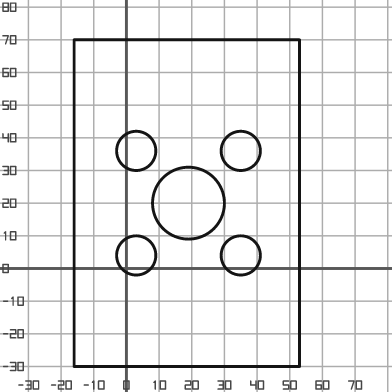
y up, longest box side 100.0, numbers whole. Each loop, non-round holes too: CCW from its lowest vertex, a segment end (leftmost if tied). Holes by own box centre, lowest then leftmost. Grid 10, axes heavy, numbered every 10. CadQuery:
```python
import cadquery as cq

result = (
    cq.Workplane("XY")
    .moveTo(-16.0, -30.0)
    .lineTo(53.0, -30.0)
    .lineTo(53.0, 70.0)
    .lineTo(-16.0, 70.0)
    .close()
    .moveTo(3.0, 4.0)
    .circle(6.0)
    .moveTo(35.0, 4.0)
    .circle(6.0)
    .moveTo(19.0, 20.0)
    .circle(11.0)
    .moveTo(3.0, 36.0)
    .circle(6.0)
    .moveTo(35.0, 36.0)
    .circle(6.0)
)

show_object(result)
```